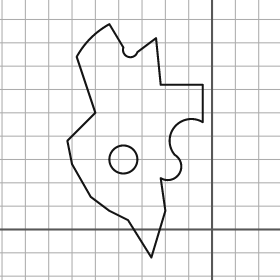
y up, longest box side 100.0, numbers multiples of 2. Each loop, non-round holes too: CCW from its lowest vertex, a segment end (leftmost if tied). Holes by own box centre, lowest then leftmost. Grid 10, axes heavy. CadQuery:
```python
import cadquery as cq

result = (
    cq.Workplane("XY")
    .moveTo(-26.0, -12.0)
    .lineTo(-20.0, 8.0)
    .lineTo(-22.0, 22.0)
    .threePointArc((-14.0, 24.0), (-16.0, 32.0))
    .threePointArc((-16.0, 44.0), (-4.0, 46.0))
    .lineTo(-4.0, 62.0)
    .lineTo(-22.0, 62.0)
    .lineTo(-24.0, 82.0)
    .lineTo(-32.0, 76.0)
    .threePointArc((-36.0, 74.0), (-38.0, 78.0))
    .lineTo(-44.0, 88.0)
    .threePointArc((-52.0, 82.0), (-58.0, 74.0))
    .lineTo(-50.0, 50.0)
    .lineTo(-62.0, 38.0)
    .lineTo(-60.0, 28.0)
    .lineTo(-52.0, 14.0)
    .lineTo(-44.0, 8.0)
    .lineTo(-36.0, 4.0)
    .close()
    .moveTo(-38.0, 30.0)
    .circle(6.0)
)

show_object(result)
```